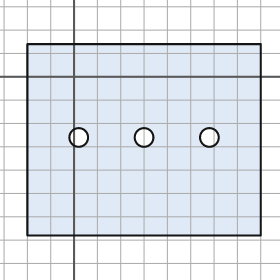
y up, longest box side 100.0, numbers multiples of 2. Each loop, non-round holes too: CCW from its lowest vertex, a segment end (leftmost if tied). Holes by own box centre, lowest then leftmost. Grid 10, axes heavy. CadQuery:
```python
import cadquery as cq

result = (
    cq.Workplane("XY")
    .moveTo(-20.0, -68.0)
    .lineTo(80.0, -68.0)
    .lineTo(80.0, 14.0)
    .lineTo(-20.0, 14.0)
    .close()
    .moveTo(2.0, -26.0)
    .circle(4.0)
    .moveTo(30.0, -26.0)
    .circle(4.0)
    .moveTo(58.0, -26.0)
    .circle(4.0)
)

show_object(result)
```